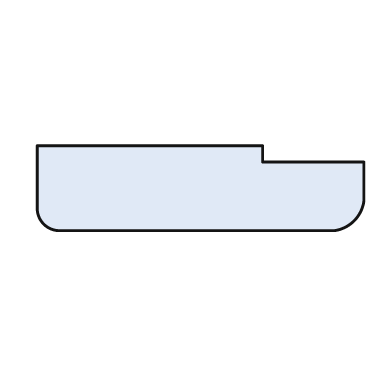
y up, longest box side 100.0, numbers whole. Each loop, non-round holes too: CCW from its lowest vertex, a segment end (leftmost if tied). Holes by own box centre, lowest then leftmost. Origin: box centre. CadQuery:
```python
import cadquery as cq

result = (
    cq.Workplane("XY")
    .moveTo(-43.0, -13.0)
    .lineTo(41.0, -13.0)
    .threePointArc((47.0, -10.0), (50.0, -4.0))
    .lineTo(50.0, 8.0)
    .lineTo(19.0, 8.0)
    .lineTo(19.0, 13.0)
    .lineTo(-50.0, 13.0)
    .lineTo(-50.0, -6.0)
    .threePointArc((-48.0, -11.0), (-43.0, -13.0))
    .close()
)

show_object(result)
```